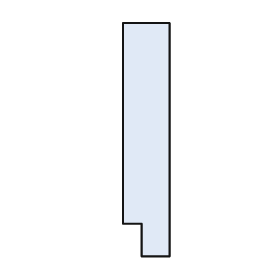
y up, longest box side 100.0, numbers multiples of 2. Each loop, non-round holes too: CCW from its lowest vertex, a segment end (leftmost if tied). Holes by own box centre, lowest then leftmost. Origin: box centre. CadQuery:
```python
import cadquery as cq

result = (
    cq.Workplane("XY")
    .moveTo(-2.0, -50.0)
    .lineTo(10.0, -50.0)
    .lineTo(10.0, 50.0)
    .lineTo(-10.0, 50.0)
    .lineTo(-10.0, -36.0)
    .lineTo(-2.0, -36.0)
    .close()
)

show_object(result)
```